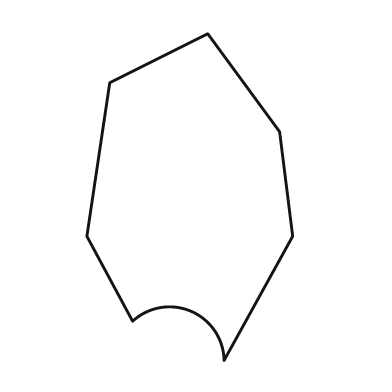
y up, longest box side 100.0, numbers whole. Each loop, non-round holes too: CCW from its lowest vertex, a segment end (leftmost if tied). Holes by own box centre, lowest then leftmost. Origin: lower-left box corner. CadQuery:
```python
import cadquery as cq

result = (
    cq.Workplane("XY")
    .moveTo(42.0, 0.0)
    .lineTo(63.0, 38.0)
    .lineTo(59.0, 70.0)
    .lineTo(37.0, 100.0)
    .lineTo(7.0, 85.0)
    .lineTo(0.0, 38.0)
    .lineTo(14.0, 12.0)
    .threePointArc((32.0, 15.0), (42.0, 0.0))
    .close()
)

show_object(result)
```